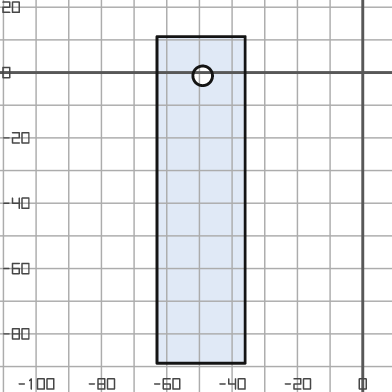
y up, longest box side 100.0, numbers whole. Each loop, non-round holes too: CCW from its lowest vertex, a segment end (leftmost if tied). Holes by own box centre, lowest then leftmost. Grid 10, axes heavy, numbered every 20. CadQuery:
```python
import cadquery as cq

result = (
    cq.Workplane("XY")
    .moveTo(-63.0, -89.0)
    .lineTo(-36.0, -89.0)
    .lineTo(-36.0, 11.0)
    .lineTo(-63.0, 11.0)
    .close()
    .moveTo(-49.0, -1.0)
    .circle(3.0)
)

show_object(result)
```